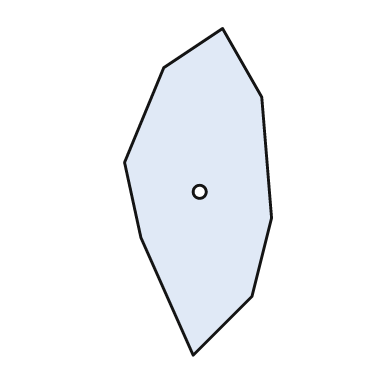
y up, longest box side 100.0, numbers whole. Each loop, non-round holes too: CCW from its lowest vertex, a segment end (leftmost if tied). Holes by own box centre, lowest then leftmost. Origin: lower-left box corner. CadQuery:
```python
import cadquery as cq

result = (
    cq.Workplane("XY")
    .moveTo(21.0, 0.0)
    .lineTo(39.0, 18.0)
    .lineTo(45.0, 42.0)
    .lineTo(42.0, 79.0)
    .lineTo(30.0, 100.0)
    .lineTo(12.0, 88.0)
    .lineTo(0.0, 59.0)
    .lineTo(5.0, 36.0)
    .close()
    .moveTo(23.0, 50.0)
    .circle(2.0)
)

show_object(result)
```